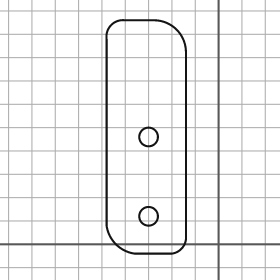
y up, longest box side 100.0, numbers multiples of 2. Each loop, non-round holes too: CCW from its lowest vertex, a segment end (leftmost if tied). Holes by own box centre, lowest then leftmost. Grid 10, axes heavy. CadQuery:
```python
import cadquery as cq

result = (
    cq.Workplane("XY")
    .moveTo(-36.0, -4.0)
    .lineTo(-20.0, -4.0)
    .threePointArc((-16.0, -2.0), (-14.0, 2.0))
    .lineTo(-14.0, 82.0)
    .threePointArc((-18.0, 92.0), (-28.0, 96.0))
    .lineTo(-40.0, 96.0)
    .threePointArc((-46.0, 94.0), (-48.0, 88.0))
    .lineTo(-48.0, 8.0)
    .threePointArc((-44.0, 0.0), (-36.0, -4.0))
    .close()
    .moveTo(-30.0, 12.0)
    .circle(4.0)
    .moveTo(-30.0, 46.0)
    .circle(4.0)
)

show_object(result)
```